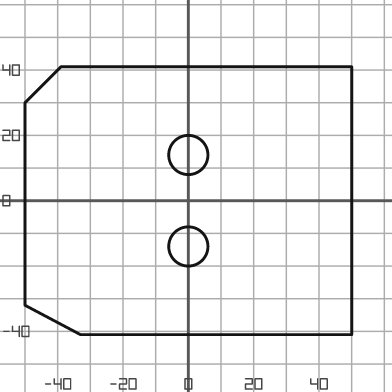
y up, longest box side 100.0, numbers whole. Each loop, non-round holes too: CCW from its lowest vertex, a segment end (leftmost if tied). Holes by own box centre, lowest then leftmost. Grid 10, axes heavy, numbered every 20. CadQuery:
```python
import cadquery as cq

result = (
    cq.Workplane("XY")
    .moveTo(-33.0, -41.0)
    .lineTo(50.0, -41.0)
    .lineTo(50.0, 41.0)
    .lineTo(-39.0, 41.0)
    .lineTo(-50.0, 30.0)
    .lineTo(-50.0, -32.0)
    .close()
    .moveTo(0.0, -14.0)
    .circle(6.0)
    .moveTo(0.0, 14.0)
    .circle(6.0)
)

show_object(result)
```